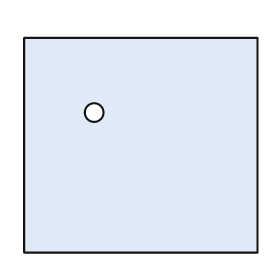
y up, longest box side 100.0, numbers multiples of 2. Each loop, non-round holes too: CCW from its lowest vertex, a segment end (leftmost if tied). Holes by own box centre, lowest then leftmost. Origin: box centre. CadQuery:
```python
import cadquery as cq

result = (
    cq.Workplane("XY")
    .moveTo(-50.0, -46.0)
    .lineTo(50.0, -46.0)
    .lineTo(50.0, 46.0)
    .lineTo(-50.0, 46.0)
    .close()
    .moveTo(-20.0, 14.0)
    .circle(4.0)
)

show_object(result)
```